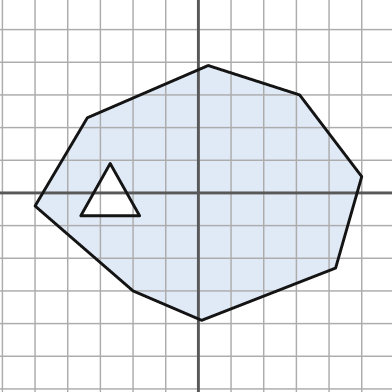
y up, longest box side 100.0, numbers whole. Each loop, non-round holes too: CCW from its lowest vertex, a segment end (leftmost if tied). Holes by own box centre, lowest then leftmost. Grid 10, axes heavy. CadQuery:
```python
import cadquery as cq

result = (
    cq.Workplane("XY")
    .moveTo(1.0, -39.0)
    .lineTo(42.0, -23.0)
    .lineTo(50.0, 5.0)
    .lineTo(31.0, 30.0)
    .lineTo(3.0, 39.0)
    .lineTo(-34.0, 23.0)
    .lineTo(-50.0, -4.0)
    .lineTo(-20.0, -30.0)
    .close()
    .moveTo(-36.0, -7.0)
    .lineTo(-18.0, -7.0)
    .lineTo(-27.0, 9.0)
    .close()
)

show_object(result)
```